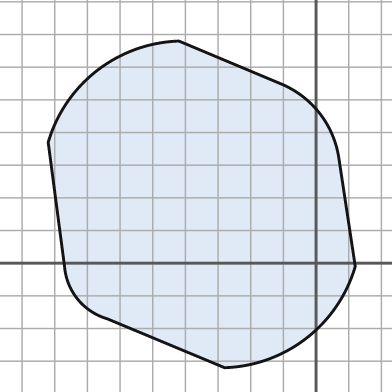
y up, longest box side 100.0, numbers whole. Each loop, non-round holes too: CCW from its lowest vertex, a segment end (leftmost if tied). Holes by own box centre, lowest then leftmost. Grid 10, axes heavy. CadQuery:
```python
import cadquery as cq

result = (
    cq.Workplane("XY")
    .moveTo(-28.0, -32.0)
    .threePointArc((-3.0, -23.0), (12.0, -1.0))
    .lineTo(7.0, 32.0)
    .threePointArc((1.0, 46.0), (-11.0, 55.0))
    .lineTo(-42.0, 68.0)
    .threePointArc((-67.0, 59.0), (-82.0, 37.0))
    .lineTo(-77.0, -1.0)
    .threePointArc((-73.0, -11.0), (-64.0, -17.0))
    .close()
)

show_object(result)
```